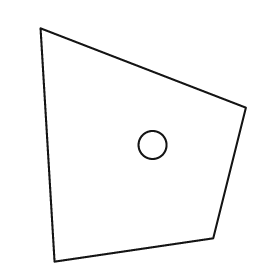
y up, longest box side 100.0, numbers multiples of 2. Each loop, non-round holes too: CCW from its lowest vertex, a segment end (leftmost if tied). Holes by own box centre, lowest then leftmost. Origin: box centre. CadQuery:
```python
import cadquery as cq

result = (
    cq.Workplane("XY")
    .moveTo(-38.0, -50.0)
    .lineTo(30.0, -40.0)
    .lineTo(44.0, 16.0)
    .lineTo(-44.0, 50.0)
    .close()
    .moveTo(4.0, 0.0)
    .circle(6.0)
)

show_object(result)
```